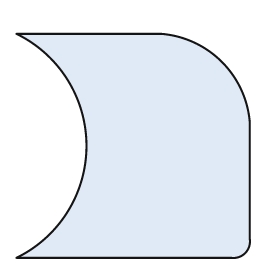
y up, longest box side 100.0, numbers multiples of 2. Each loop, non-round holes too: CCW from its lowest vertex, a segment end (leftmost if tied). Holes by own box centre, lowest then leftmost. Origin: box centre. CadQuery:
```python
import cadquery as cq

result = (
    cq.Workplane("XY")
    .moveTo(-50.0, -48.0)
    .lineTo(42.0, -48.0)
    .threePointArc((48.0, -46.0), (50.0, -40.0))
    .lineTo(50.0, 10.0)
    .threePointArc((38.0, 36.0), (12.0, 48.0))
    .lineTo(-50.0, 48.0)
    .threePointArc((-20.0, 0.0), (-50.0, -48.0))
    .close()
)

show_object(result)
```